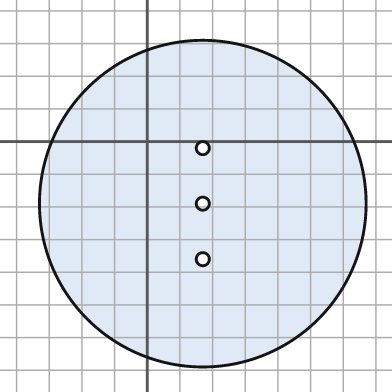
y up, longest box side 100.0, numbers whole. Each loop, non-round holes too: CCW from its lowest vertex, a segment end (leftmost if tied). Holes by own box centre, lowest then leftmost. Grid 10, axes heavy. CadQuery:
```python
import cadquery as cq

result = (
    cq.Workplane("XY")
    .moveTo(17.0, -19.0)
    .circle(50.0)
    .moveTo(17.0, -36.0)
    .circle(2.0)
    .moveTo(17.0, -19.0)
    .circle(2.0)
    .moveTo(17.0, -2.0)
    .circle(2.0)
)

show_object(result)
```